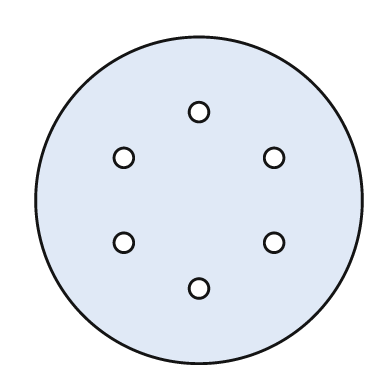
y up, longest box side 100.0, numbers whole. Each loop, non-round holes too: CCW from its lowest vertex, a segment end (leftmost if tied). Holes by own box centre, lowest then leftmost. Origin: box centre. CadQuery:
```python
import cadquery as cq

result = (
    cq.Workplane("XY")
    .moveTo(0.0, 0.0)
    .circle(50.0)
    .moveTo(0.0, -27.0)
    .circle(3.0)
    .moveTo(-23.0, -13.0)
    .circle(3.0)
    .moveTo(23.0, -13.0)
    .circle(3.0)
    .moveTo(-23.0, 13.0)
    .circle(3.0)
    .moveTo(23.0, 13.0)
    .circle(3.0)
    .moveTo(0.0, 27.0)
    .circle(3.0)
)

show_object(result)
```